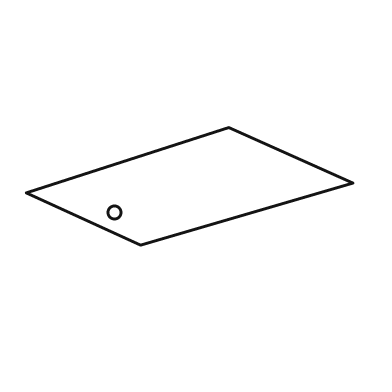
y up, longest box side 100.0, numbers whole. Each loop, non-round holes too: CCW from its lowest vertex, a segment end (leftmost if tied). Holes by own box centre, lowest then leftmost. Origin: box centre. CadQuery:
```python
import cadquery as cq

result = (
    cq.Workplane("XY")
    .moveTo(-15.0, -18.0)
    .lineTo(50.0, 1.0)
    .lineTo(12.0, 18.0)
    .lineTo(-50.0, -2.0)
    .close()
    .moveTo(-23.0, -8.0)
    .circle(2.0)
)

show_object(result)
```